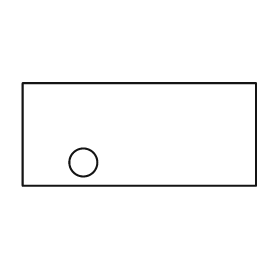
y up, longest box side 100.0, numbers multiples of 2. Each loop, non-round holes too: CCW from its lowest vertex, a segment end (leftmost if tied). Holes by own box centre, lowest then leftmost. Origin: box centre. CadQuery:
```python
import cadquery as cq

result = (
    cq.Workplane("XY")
    .moveTo(-50.0, -22.0)
    .lineTo(50.0, -22.0)
    .lineTo(50.0, 22.0)
    .lineTo(-50.0, 22.0)
    .close()
    .moveTo(-24.0, -12.0)
    .circle(6.0)
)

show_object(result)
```